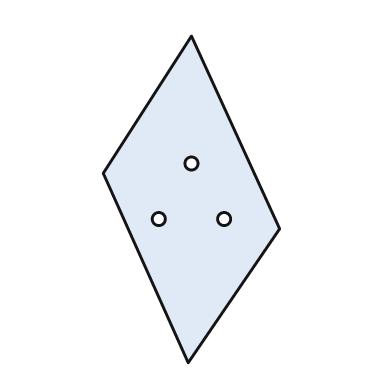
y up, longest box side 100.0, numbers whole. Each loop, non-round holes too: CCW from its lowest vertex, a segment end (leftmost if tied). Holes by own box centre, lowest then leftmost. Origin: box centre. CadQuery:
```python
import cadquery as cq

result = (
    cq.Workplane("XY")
    .moveTo(-1.0, -50.0)
    .lineTo(27.0, -9.0)
    .lineTo(0.0, 50.0)
    .lineTo(-27.0, 8.0)
    .close()
    .moveTo(-10.0, -6.0)
    .circle(2.0)
    .moveTo(10.0, -6.0)
    .circle(2.0)
    .moveTo(0.0, 11.0)
    .circle(2.0)
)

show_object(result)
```